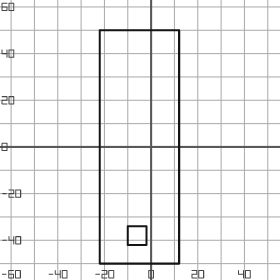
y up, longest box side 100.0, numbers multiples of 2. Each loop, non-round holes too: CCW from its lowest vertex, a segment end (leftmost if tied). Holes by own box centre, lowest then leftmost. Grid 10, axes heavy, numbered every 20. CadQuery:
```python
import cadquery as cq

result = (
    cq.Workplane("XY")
    .moveTo(-22.0, -50.0)
    .lineTo(12.0, -50.0)
    .lineTo(12.0, 50.0)
    .lineTo(-22.0, 50.0)
    .close()
    .moveTo(-10.0, -42.0)
    .lineTo(-2.0, -42.0)
    .lineTo(-2.0, -34.0)
    .lineTo(-10.0, -34.0)
    .close()
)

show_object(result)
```